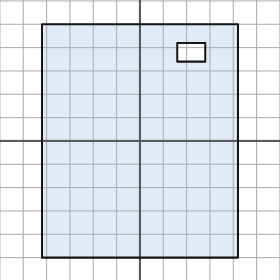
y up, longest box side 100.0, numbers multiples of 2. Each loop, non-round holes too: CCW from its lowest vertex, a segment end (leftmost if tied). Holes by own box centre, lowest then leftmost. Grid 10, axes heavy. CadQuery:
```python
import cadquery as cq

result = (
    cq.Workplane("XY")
    .moveTo(-42.0, -50.0)
    .lineTo(42.0, -50.0)
    .lineTo(42.0, 50.0)
    .lineTo(-42.0, 50.0)
    .close()
    .moveTo(16.0, 34.0)
    .lineTo(28.0, 34.0)
    .lineTo(28.0, 42.0)
    .lineTo(16.0, 42.0)
    .close()
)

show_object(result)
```